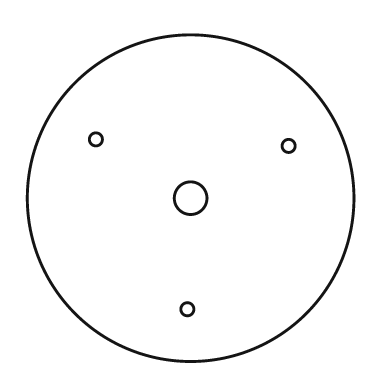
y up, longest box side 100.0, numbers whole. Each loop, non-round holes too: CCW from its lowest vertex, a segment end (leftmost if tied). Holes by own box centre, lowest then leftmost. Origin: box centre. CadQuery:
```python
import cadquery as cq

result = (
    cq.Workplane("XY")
    .moveTo(0.0, 0.0)
    .circle(50.0)
    .moveTo(-1.0, -34.0)
    .circle(2.0)
    .moveTo(0.0, 0.0)
    .circle(5.0)
    .moveTo(30.0, 16.0)
    .circle(2.0)
    .moveTo(-29.0, 18.0)
    .circle(2.0)
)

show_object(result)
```